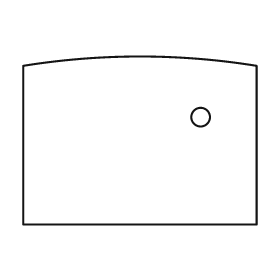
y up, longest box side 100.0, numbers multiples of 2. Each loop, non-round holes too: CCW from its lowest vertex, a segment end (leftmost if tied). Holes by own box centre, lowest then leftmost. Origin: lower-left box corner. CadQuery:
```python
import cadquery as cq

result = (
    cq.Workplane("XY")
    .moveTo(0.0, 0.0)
    .lineTo(100.0, 0.0)
    .lineTo(100.0, 68.0)
    .threePointArc((50.0, 72.0), (0.0, 68.0))
    .close()
    .moveTo(76.0, 46.0)
    .circle(4.0)
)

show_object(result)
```